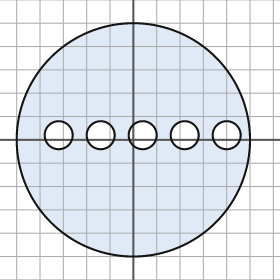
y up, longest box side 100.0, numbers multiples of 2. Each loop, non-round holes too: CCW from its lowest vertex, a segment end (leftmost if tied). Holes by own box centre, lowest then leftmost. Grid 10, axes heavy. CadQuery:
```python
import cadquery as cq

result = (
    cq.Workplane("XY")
    .moveTo(0.0, 0.0)
    .circle(50.0)
    .moveTo(-32.0, 2.0)
    .circle(6.0)
    .moveTo(-14.0, 2.0)
    .circle(6.0)
    .moveTo(4.0, 2.0)
    .circle(6.0)
    .moveTo(22.0, 2.0)
    .circle(6.0)
    .moveTo(40.0, 2.0)
    .circle(6.0)
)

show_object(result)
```